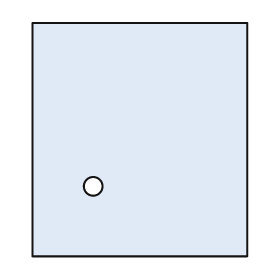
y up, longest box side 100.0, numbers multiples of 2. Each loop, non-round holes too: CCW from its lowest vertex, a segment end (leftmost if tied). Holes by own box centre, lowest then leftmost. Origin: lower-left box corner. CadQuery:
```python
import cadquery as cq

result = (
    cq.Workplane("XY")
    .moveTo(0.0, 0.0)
    .lineTo(92.0, 0.0)
    .lineTo(92.0, 100.0)
    .lineTo(0.0, 100.0)
    .close()
    .moveTo(26.0, 30.0)
    .circle(4.0)
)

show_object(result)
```